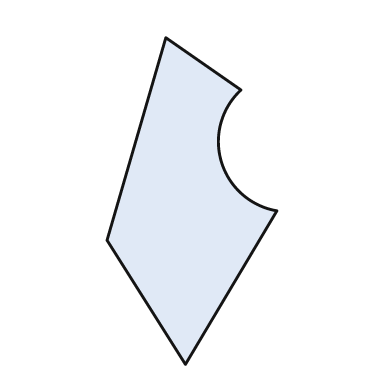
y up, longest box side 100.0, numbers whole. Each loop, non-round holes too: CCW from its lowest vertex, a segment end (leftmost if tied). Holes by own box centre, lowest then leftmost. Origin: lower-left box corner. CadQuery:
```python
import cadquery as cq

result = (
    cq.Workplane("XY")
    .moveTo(24.0, 0.0)
    .lineTo(52.0, 47.0)
    .threePointArc((35.0, 62.0), (41.0, 84.0))
    .lineTo(18.0, 100.0)
    .lineTo(0.0, 38.0)
    .close()
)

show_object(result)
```